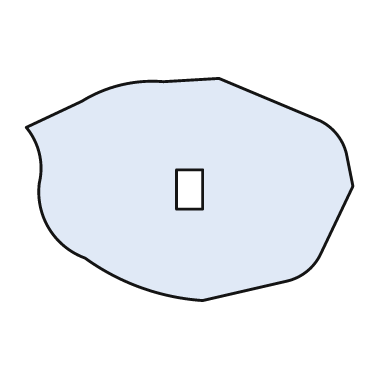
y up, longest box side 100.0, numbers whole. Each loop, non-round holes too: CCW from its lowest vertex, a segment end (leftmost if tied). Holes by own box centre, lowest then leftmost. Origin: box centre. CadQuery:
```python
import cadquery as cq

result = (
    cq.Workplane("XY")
    .moveTo(4.0, -34.0)
    .lineTo(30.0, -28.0)
    .threePointArc((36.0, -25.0), (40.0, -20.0))
    .lineTo(50.0, 1.0)
    .lineTo(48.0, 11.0)
    .threePointArc((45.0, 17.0), (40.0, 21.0))
    .lineTo(9.0, 34.0)
    .lineTo(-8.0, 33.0)
    .threePointArc((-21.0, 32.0), (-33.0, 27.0))
    .lineTo(-50.0, 19.0)
    .threePointArc((-46.0, 11.0), (-46.0, 2.0))
    .threePointArc((-43.0, -12.0), (-32.0, -21.0))
    .threePointArc((-15.0, -30.0), (4.0, -34.0))
    .close()
    .moveTo(-4.0, -6.0)
    .lineTo(4.0, -6.0)
    .lineTo(4.0, 6.0)
    .lineTo(-4.0, 6.0)
    .close()
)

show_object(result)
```